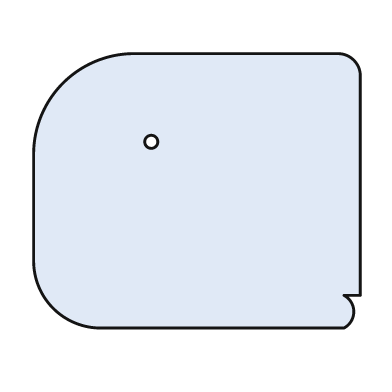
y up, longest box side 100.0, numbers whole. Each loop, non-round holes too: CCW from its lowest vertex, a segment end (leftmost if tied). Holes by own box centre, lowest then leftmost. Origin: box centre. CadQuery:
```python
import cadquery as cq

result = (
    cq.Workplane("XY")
    .moveTo(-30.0, -42.0)
    .lineTo(45.0, -42.0)
    .threePointArc((48.0, -37.0), (45.0, -32.0))
    .lineTo(50.0, -32.0)
    .lineTo(50.0, 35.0)
    .threePointArc((48.0, 40.0), (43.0, 42.0))
    .lineTo(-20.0, 42.0)
    .threePointArc((-41.0, 33.0), (-50.0, 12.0))
    .lineTo(-50.0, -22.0)
    .threePointArc((-44.0, -36.0), (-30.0, -42.0))
    .close()
    .moveTo(-14.0, 15.0)
    .circle(2.0)
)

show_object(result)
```